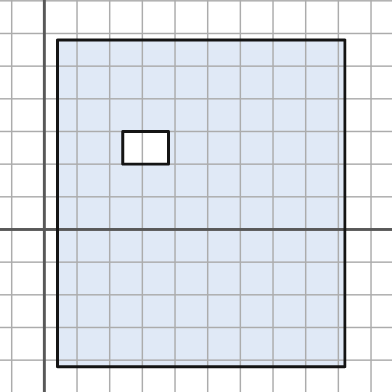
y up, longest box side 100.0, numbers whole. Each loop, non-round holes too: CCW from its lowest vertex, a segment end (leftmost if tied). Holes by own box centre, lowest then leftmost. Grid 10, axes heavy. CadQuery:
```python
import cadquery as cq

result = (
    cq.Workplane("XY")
    .moveTo(4.0, -42.0)
    .lineTo(92.0, -42.0)
    .lineTo(92.0, 58.0)
    .lineTo(4.0, 58.0)
    .close()
    .moveTo(24.0, 20.0)
    .lineTo(38.0, 20.0)
    .lineTo(38.0, 30.0)
    .lineTo(24.0, 30.0)
    .close()
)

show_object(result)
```